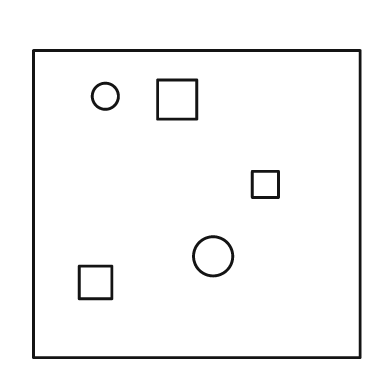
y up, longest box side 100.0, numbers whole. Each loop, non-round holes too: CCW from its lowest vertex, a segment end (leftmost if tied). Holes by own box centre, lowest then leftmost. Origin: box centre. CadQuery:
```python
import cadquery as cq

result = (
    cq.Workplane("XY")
    .moveTo(-50.0, -47.0)
    .lineTo(50.0, -47.0)
    .lineTo(50.0, 47.0)
    .lineTo(-50.0, 47.0)
    .close()
    .moveTo(-36.0, -29.0)
    .lineTo(-26.0, -29.0)
    .lineTo(-26.0, -19.0)
    .lineTo(-36.0, -19.0)
    .close()
    .moveTo(5.0, -16.0)
    .circle(6.0)
    .moveTo(17.0, 2.0)
    .lineTo(25.0, 2.0)
    .lineTo(25.0, 10.0)
    .lineTo(17.0, 10.0)
    .close()
    .moveTo(-12.0, 26.0)
    .lineTo(0.0, 26.0)
    .lineTo(0.0, 38.0)
    .lineTo(-12.0, 38.0)
    .close()
    .moveTo(-28.0, 33.0)
    .circle(4.0)
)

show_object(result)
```